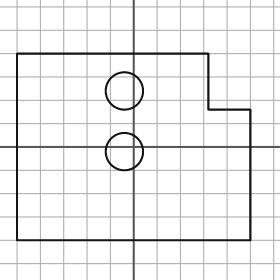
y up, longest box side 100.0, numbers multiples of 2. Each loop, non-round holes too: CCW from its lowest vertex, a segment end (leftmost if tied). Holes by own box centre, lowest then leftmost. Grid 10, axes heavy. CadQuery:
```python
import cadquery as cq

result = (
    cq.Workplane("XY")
    .moveTo(-50.0, -40.0)
    .lineTo(50.0, -40.0)
    .lineTo(50.0, 16.0)
    .lineTo(32.0, 16.0)
    .lineTo(32.0, 40.0)
    .lineTo(-50.0, 40.0)
    .close()
    .moveTo(-4.0, -2.0)
    .circle(8.0)
    .moveTo(-4.0, 24.0)
    .circle(8.0)
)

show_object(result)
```